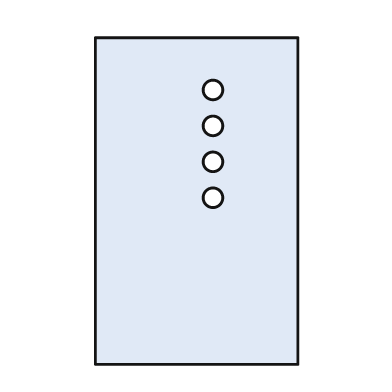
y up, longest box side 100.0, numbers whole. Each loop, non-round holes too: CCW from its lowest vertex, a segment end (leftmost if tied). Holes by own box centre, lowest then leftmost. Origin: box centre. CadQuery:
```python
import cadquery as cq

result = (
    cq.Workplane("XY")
    .moveTo(-31.0, -50.0)
    .lineTo(31.0, -50.0)
    .lineTo(31.0, 50.0)
    .lineTo(-31.0, 50.0)
    .close()
    .moveTo(5.0, 1.0)
    .circle(3.0)
    .moveTo(5.0, 12.0)
    .circle(3.0)
    .moveTo(5.0, 23.0)
    .circle(3.0)
    .moveTo(5.0, 34.0)
    .circle(3.0)
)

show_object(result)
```